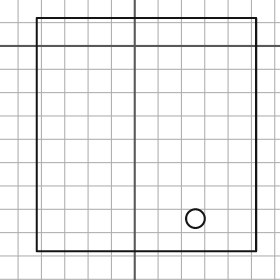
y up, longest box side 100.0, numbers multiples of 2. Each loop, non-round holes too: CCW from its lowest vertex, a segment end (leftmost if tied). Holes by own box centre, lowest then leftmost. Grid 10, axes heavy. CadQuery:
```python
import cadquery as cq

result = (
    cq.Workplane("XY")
    .moveTo(-42.0, -88.0)
    .lineTo(52.0, -88.0)
    .lineTo(52.0, 12.0)
    .lineTo(-42.0, 12.0)
    .close()
    .moveTo(26.0, -74.0)
    .circle(4.0)
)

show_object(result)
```